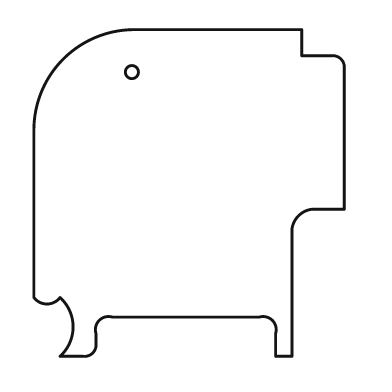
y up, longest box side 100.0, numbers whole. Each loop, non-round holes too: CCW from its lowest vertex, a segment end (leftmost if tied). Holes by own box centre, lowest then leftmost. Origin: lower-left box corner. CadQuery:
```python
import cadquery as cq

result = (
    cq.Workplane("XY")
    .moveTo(8.0, 0.0)
    .lineTo(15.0, 0.0)
    .threePointArc((18.0, 1.0), (19.0, 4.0))
    .lineTo(19.0, 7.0)
    .threePointArc((20.0, 11.0), (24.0, 12.0))
    .lineTo(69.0, 12.0)
    .threePointArc((73.0, 11.0), (74.0, 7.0))
    .lineTo(74.0, 0.0)
    .lineTo(79.0, 0.0)
    .lineTo(79.0, 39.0)
    .threePointArc((81.0, 43.0), (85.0, 45.0))
    .lineTo(95.0, 45.0)
    .lineTo(95.0, 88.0)
    .threePointArc((94.0, 91.0), (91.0, 92.0))
    .lineTo(82.0, 92.0)
    .lineTo(82.0, 100.0)
    .lineTo(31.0, 100.0)
    .threePointArc((9.0, 91.0), (0.0, 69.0))
    .lineTo(0.0, 18.0)
    .threePointArc((4.0, 16.0), (8.0, 18.0))
    .threePointArc((12.0, 9.0), (8.0, 0.0))
    .close()
    .moveTo(30.0, 87.0)
    .circle(2.0)
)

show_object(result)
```